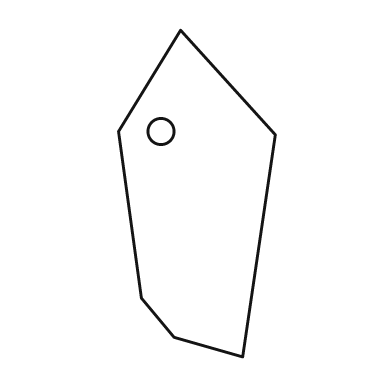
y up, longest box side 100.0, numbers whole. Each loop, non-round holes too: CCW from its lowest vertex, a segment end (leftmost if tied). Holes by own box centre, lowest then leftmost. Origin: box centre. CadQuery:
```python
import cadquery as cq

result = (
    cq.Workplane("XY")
    .moveTo(14.0, -50.0)
    .lineTo(24.0, 18.0)
    .lineTo(-5.0, 50.0)
    .lineTo(-24.0, 19.0)
    .lineTo(-17.0, -32.0)
    .lineTo(-7.0, -44.0)
    .close()
    .moveTo(-11.0, 19.0)
    .circle(4.0)
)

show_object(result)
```